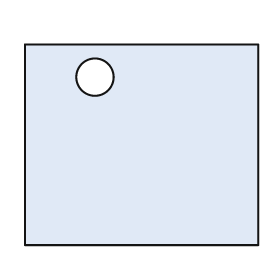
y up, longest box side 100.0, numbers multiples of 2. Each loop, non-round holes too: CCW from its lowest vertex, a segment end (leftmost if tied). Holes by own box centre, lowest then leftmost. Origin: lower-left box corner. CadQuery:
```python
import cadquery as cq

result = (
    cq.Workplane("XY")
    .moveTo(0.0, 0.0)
    .lineTo(100.0, 0.0)
    .lineTo(100.0, 86.0)
    .lineTo(0.0, 86.0)
    .close()
    .moveTo(30.0, 72.0)
    .circle(8.0)
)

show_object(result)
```